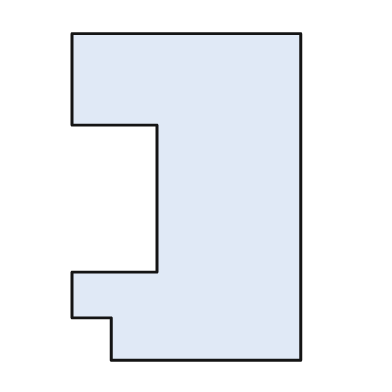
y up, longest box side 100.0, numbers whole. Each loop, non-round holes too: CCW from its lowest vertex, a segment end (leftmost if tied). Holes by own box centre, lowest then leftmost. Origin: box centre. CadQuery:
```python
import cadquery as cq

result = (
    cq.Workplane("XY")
    .moveTo(-23.0, -50.0)
    .lineTo(35.0, -50.0)
    .lineTo(35.0, 50.0)
    .lineTo(-35.0, 50.0)
    .lineTo(-35.0, 22.0)
    .lineTo(-9.0, 22.0)
    .lineTo(-9.0, -23.0)
    .lineTo(-35.0, -23.0)
    .lineTo(-35.0, -37.0)
    .lineTo(-23.0, -37.0)
    .close()
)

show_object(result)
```